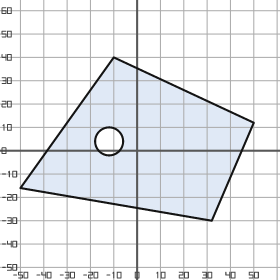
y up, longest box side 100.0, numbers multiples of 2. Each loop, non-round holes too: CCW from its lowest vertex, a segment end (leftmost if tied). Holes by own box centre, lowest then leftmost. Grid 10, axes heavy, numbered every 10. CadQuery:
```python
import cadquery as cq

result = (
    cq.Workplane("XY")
    .moveTo(32.0, -30.0)
    .lineTo(50.0, 12.0)
    .lineTo(-10.0, 40.0)
    .lineTo(-50.0, -16.0)
    .close()
    .moveTo(-12.0, 4.0)
    .circle(6.0)
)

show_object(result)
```